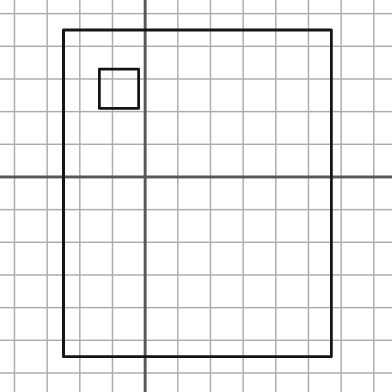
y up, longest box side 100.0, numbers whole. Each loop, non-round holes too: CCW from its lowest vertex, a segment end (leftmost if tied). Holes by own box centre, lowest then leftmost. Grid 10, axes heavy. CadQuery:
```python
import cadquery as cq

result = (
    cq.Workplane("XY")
    .moveTo(-25.0, -55.0)
    .lineTo(57.0, -55.0)
    .lineTo(57.0, 45.0)
    .lineTo(-25.0, 45.0)
    .close()
    .moveTo(-14.0, 21.0)
    .lineTo(-2.0, 21.0)
    .lineTo(-2.0, 33.0)
    .lineTo(-14.0, 33.0)
    .close()
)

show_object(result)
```